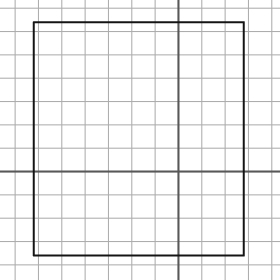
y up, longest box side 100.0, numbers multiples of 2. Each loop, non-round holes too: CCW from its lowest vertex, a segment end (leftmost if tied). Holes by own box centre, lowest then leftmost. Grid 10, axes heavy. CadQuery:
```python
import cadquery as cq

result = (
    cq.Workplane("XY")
    .moveTo(-62.0, -36.0)
    .lineTo(28.0, -36.0)
    .lineTo(28.0, 64.0)
    .lineTo(-62.0, 64.0)
    .close()
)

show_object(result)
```